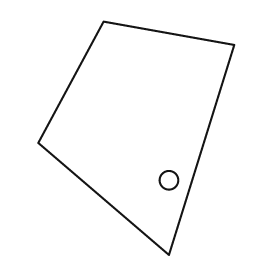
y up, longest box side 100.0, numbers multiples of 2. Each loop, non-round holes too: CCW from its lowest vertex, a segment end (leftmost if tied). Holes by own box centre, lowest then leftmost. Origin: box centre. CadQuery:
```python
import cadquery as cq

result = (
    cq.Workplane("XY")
    .moveTo(14.0, -50.0)
    .lineTo(42.0, 40.0)
    .lineTo(-14.0, 50.0)
    .lineTo(-42.0, -2.0)
    .close()
    .moveTo(14.0, -18.0)
    .circle(4.0)
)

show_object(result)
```